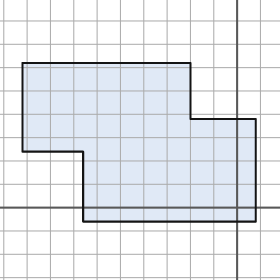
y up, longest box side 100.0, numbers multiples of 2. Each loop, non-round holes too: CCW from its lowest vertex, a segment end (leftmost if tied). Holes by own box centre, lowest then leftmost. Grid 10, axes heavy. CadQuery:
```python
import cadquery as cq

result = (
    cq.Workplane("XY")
    .moveTo(-66.0, -6.0)
    .lineTo(8.0, -6.0)
    .lineTo(8.0, 38.0)
    .lineTo(-20.0, 38.0)
    .lineTo(-20.0, 62.0)
    .lineTo(-92.0, 62.0)
    .lineTo(-92.0, 24.0)
    .lineTo(-66.0, 24.0)
    .close()
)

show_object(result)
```